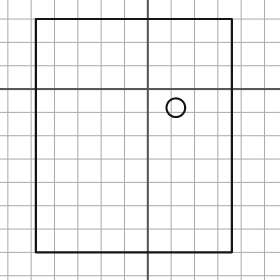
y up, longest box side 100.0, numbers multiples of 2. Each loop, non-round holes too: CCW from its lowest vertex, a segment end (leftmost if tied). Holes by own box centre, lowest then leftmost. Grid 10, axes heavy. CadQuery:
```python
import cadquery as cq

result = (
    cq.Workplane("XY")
    .moveTo(-48.0, -70.0)
    .lineTo(36.0, -70.0)
    .lineTo(36.0, 30.0)
    .lineTo(-48.0, 30.0)
    .close()
    .moveTo(12.0, -8.0)
    .circle(4.0)
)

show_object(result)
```